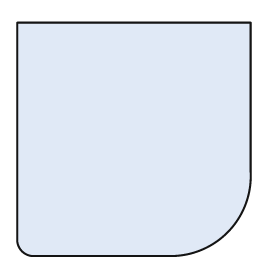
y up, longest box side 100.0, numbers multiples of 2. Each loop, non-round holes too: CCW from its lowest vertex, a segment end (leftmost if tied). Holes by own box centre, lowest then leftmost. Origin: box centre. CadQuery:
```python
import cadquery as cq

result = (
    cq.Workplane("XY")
    .moveTo(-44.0, -50.0)
    .lineTo(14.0, -50.0)
    .threePointArc((40.0, -40.0), (50.0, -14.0))
    .lineTo(50.0, 50.0)
    .lineTo(-50.0, 50.0)
    .lineTo(-50.0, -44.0)
    .threePointArc((-48.0, -48.0), (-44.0, -50.0))
    .close()
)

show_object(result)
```